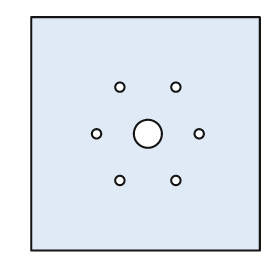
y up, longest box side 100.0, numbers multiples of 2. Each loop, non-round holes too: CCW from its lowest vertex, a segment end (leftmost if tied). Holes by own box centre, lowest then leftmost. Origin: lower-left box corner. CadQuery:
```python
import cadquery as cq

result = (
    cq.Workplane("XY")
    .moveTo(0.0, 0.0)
    .lineTo(98.0, 0.0)
    .lineTo(98.0, 100.0)
    .lineTo(0.0, 100.0)
    .close()
    .moveTo(38.0, 30.0)
    .circle(2.0)
    .moveTo(62.0, 30.0)
    .circle(2.0)
    .moveTo(28.0, 50.0)
    .circle(2.0)
    .moveTo(50.0, 50.0)
    .circle(6.0)
    .moveTo(72.0, 50.0)
    .circle(2.0)
    .moveTo(38.0, 70.0)
    .circle(2.0)
    .moveTo(62.0, 70.0)
    .circle(2.0)
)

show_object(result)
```